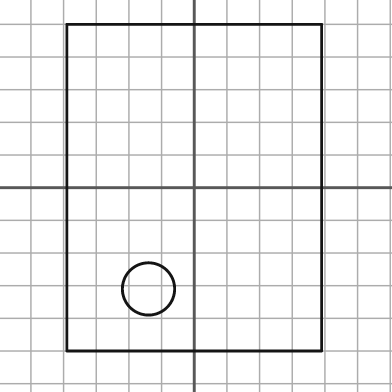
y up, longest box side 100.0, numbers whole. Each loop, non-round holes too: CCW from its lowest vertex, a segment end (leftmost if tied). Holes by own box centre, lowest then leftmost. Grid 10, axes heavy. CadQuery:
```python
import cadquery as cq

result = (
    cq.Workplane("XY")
    .moveTo(-39.0, -50.0)
    .lineTo(39.0, -50.0)
    .lineTo(39.0, 50.0)
    .lineTo(-39.0, 50.0)
    .close()
    .moveTo(-14.0, -31.0)
    .circle(8.0)
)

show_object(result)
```